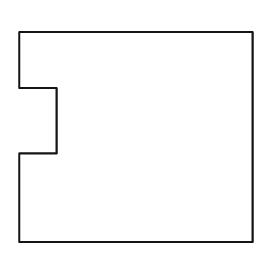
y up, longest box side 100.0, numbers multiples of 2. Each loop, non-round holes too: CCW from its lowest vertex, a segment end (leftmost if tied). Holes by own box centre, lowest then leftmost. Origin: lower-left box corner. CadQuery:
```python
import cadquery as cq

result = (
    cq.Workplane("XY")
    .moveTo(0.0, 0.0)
    .lineTo(100.0, 0.0)
    .lineTo(100.0, 90.0)
    .lineTo(0.0, 90.0)
    .lineTo(0.0, 66.0)
    .lineTo(16.0, 66.0)
    .lineTo(16.0, 38.0)
    .lineTo(0.0, 38.0)
    .close()
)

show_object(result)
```